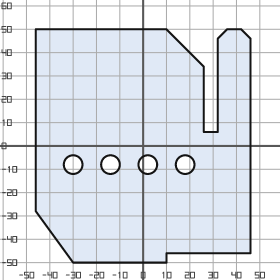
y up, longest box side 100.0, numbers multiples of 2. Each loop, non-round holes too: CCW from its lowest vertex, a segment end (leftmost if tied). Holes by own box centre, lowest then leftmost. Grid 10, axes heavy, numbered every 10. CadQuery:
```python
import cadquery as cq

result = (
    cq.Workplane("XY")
    .moveTo(-30.0, -50.0)
    .lineTo(10.0, -50.0)
    .lineTo(10.0, -46.0)
    .lineTo(46.0, -46.0)
    .lineTo(46.0, 46.0)
    .lineTo(42.0, 50.0)
    .lineTo(36.0, 50.0)
    .lineTo(32.0, 46.0)
    .lineTo(32.0, 6.0)
    .lineTo(26.0, 6.0)
    .lineTo(26.0, 34.0)
    .lineTo(10.0, 50.0)
    .lineTo(-46.0, 50.0)
    .lineTo(-46.0, -28.0)
    .close()
    .moveTo(-30.0, -8.0)
    .circle(4.0)
    .moveTo(-14.0, -8.0)
    .circle(4.0)
    .moveTo(2.0, -8.0)
    .circle(4.0)
    .moveTo(18.0, -8.0)
    .circle(4.0)
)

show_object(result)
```